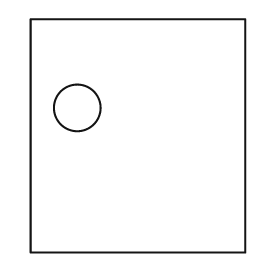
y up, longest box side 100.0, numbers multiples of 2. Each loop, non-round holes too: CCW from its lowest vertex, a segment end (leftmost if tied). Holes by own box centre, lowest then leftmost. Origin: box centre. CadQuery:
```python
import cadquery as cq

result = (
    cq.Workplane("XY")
    .moveTo(-46.0, -50.0)
    .lineTo(46.0, -50.0)
    .lineTo(46.0, 50.0)
    .lineTo(-46.0, 50.0)
    .close()
    .moveTo(-26.0, 12.0)
    .circle(10.0)
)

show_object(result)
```